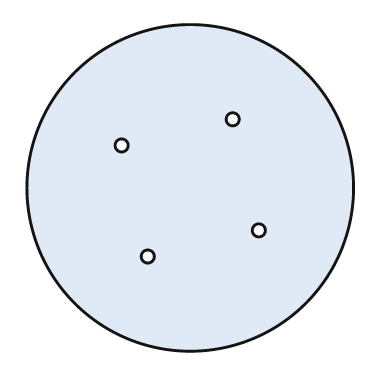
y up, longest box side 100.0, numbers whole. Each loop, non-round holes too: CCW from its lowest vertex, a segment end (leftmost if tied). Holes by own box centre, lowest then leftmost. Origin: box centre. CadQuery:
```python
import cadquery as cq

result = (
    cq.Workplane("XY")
    .moveTo(0.0, 0.0)
    .circle(50.0)
    .moveTo(-13.0, -21.0)
    .circle(2.0)
    .moveTo(21.0, -13.0)
    .circle(2.0)
    .moveTo(-21.0, 13.0)
    .circle(2.0)
    .moveTo(13.0, 21.0)
    .circle(2.0)
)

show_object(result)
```